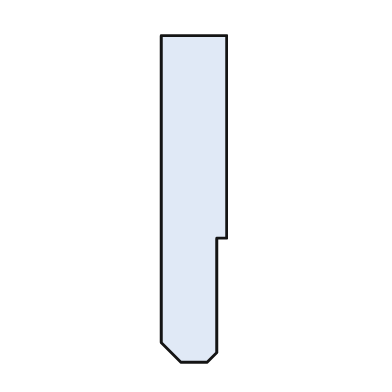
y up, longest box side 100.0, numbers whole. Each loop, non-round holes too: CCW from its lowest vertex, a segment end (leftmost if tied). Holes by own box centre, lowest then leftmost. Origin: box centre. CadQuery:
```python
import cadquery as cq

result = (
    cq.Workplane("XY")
    .moveTo(-4.0, -50.0)
    .lineTo(4.0, -50.0)
    .lineTo(7.0, -47.0)
    .lineTo(7.0, -12.0)
    .lineTo(10.0, -12.0)
    .lineTo(10.0, 50.0)
    .lineTo(-10.0, 50.0)
    .lineTo(-10.0, -44.0)
    .close()
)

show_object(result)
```